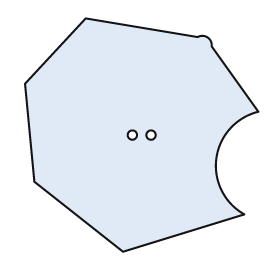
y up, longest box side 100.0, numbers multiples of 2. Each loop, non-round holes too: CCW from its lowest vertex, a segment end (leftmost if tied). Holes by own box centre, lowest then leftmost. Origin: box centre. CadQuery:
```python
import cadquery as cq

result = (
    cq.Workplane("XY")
    .moveTo(-8.0, -50.0)
    .lineTo(44.0, -34.0)
    .threePointArc((32.0, -10.0), (50.0, 10.0))
    .lineTo(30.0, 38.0)
    .threePointArc((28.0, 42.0), (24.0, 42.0))
    .lineTo(-24.0, 50.0)
    .lineTo(-50.0, 22.0)
    .lineTo(-46.0, -20.0)
    .close()
    .moveTo(-4.0, 0.0)
    .circle(2.0)
    .moveTo(4.0, 0.0)
    .circle(2.0)
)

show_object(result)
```